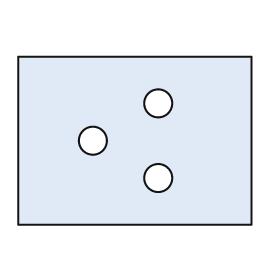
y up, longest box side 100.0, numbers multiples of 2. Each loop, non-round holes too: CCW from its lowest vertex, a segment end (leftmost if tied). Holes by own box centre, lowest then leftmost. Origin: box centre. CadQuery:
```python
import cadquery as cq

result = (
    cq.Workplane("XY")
    .moveTo(-50.0, -36.0)
    .lineTo(50.0, -36.0)
    .lineTo(50.0, 36.0)
    .lineTo(-50.0, 36.0)
    .close()
    .moveTo(10.0, -16.0)
    .circle(6.0)
    .moveTo(-18.0, 0.0)
    .circle(6.0)
    .moveTo(10.0, 16.0)
    .circle(6.0)
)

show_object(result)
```